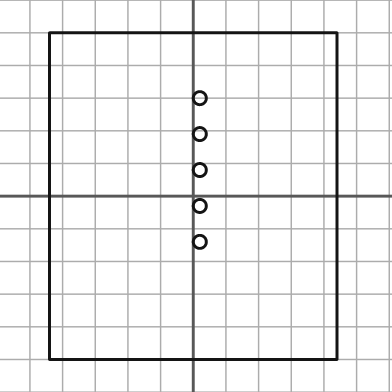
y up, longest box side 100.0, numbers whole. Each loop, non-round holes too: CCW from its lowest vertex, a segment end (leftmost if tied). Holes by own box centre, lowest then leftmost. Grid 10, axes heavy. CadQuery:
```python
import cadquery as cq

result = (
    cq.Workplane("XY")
    .moveTo(-44.0, -50.0)
    .lineTo(44.0, -50.0)
    .lineTo(44.0, 50.0)
    .lineTo(-44.0, 50.0)
    .close()
    .moveTo(2.0, -14.0)
    .circle(2.0)
    .moveTo(2.0, -3.0)
    .circle(2.0)
    .moveTo(2.0, 8.0)
    .circle(2.0)
    .moveTo(2.0, 19.0)
    .circle(2.0)
    .moveTo(2.0, 30.0)
    .circle(2.0)
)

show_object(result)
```